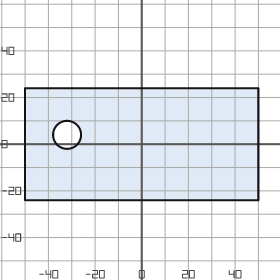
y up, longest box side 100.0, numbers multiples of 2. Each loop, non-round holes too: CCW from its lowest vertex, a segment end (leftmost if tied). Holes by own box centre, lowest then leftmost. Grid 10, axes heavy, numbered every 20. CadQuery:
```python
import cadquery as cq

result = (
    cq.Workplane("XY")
    .moveTo(-50.0, -24.0)
    .lineTo(50.0, -24.0)
    .lineTo(50.0, 24.0)
    .lineTo(-50.0, 24.0)
    .close()
    .moveTo(-32.0, 4.0)
    .circle(6.0)
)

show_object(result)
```